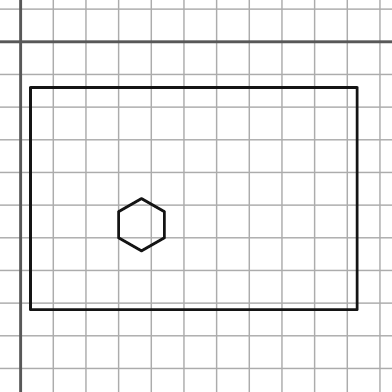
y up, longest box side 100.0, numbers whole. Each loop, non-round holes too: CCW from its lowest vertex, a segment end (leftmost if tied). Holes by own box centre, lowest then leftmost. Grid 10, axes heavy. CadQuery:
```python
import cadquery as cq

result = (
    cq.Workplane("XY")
    .moveTo(3.0, -82.0)
    .lineTo(103.0, -82.0)
    .lineTo(103.0, -14.0)
    .lineTo(3.0, -14.0)
    .close()
    .moveTo(37.0, -64.0)
    .lineTo(44.0, -60.0)
    .lineTo(44.0, -52.0)
    .lineTo(37.0, -48.0)
    .lineTo(30.0, -52.0)
    .lineTo(30.0, -60.0)
    .close()
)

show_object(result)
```